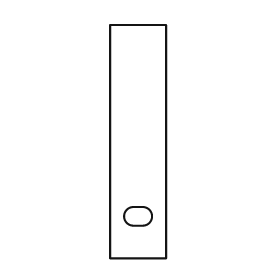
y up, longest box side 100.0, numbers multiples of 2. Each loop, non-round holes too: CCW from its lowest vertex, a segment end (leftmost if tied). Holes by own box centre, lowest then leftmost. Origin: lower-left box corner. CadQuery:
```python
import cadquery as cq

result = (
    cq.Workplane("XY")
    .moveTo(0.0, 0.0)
    .lineTo(24.0, 0.0)
    .lineTo(24.0, 100.0)
    .lineTo(0.0, 100.0)
    .close()
    .moveTo(10.0, 14.0)
    .lineTo(14.0, 14.0)
    .threePointArc((18.0, 18.0), (14.0, 22.0))
    .lineTo(10.0, 22.0)
    .threePointArc((6.0, 18.0), (10.0, 14.0))
    .close()
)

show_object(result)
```